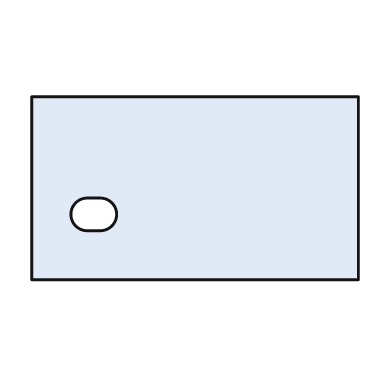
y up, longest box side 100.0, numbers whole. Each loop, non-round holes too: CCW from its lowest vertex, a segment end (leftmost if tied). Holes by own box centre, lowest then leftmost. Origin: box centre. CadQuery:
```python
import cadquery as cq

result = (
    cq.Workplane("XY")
    .moveTo(-50.0, -28.0)
    .lineTo(50.0, -28.0)
    .lineTo(50.0, 28.0)
    .lineTo(-50.0, 28.0)
    .close()
    .moveTo(-33.0, -13.0)
    .lineTo(-29.0, -13.0)
    .threePointArc((-24.0, -8.0), (-29.0, -3.0))
    .lineTo(-33.0, -3.0)
    .threePointArc((-38.0, -8.0), (-33.0, -13.0))
    .close()
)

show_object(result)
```